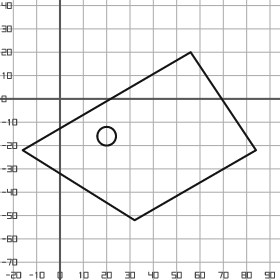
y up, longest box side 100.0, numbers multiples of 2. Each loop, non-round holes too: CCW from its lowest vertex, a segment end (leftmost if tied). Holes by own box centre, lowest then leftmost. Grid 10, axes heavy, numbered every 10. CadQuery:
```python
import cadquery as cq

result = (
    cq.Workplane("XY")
    .moveTo(32.0, -52.0)
    .lineTo(84.0, -22.0)
    .lineTo(56.0, 20.0)
    .lineTo(-16.0, -22.0)
    .close()
    .moveTo(20.0, -16.0)
    .circle(4.0)
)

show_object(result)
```